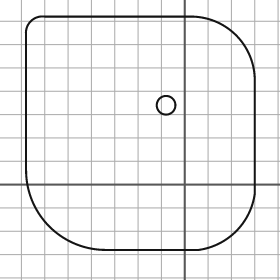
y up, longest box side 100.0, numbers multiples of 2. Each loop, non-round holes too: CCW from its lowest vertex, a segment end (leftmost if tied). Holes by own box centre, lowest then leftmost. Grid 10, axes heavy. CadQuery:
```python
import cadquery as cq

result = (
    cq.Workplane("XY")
    .moveTo(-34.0, -28.0)
    .lineTo(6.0, -28.0)
    .threePointArc((22.0, -20.0), (30.0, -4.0))
    .lineTo(30.0, 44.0)
    .threePointArc((22.0, 64.0), (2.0, 72.0))
    .lineTo(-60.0, 72.0)
    .threePointArc((-66.0, 70.0), (-68.0, 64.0))
    .lineTo(-68.0, 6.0)
    .threePointArc((-58.0, -18.0), (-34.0, -28.0))
    .close()
    .moveTo(-8.0, 34.0)
    .circle(4.0)
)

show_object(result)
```